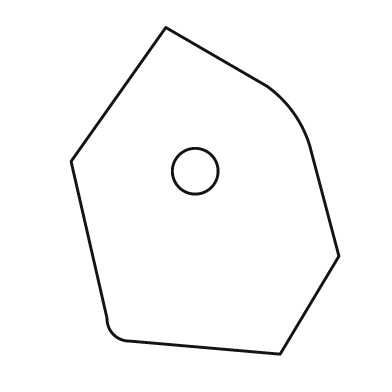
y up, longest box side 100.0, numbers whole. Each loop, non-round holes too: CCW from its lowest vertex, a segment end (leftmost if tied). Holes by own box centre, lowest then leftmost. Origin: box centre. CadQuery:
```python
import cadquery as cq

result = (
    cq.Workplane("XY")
    .moveTo(23.0, -50.0)
    .lineTo(41.0, -20.0)
    .lineTo(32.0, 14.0)
    .threePointArc((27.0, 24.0), (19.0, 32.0))
    .lineTo(-12.0, 50.0)
    .lineTo(-41.0, 9.0)
    .lineTo(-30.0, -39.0)
    .threePointArc((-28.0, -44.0), (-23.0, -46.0))
    .close()
    .moveTo(-3.0, 6.0)
    .circle(7.0)
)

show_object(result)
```